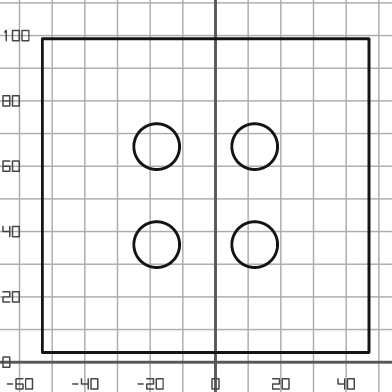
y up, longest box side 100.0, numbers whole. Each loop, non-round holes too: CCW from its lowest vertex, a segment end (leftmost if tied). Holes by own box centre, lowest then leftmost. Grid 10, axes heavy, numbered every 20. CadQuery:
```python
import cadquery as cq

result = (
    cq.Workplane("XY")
    .moveTo(-53.0, 3.0)
    .lineTo(47.0, 3.0)
    .lineTo(47.0, 99.0)
    .lineTo(-53.0, 99.0)
    .close()
    .moveTo(-18.0, 36.0)
    .circle(7.0)
    .moveTo(12.0, 36.0)
    .circle(7.0)
    .moveTo(-18.0, 66.0)
    .circle(7.0)
    .moveTo(12.0, 66.0)
    .circle(7.0)
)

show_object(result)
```